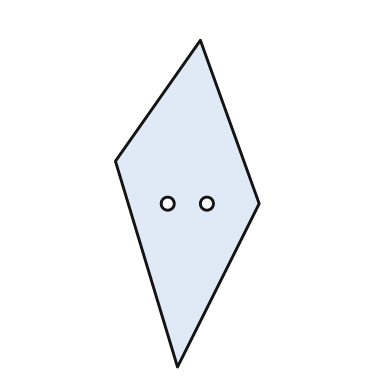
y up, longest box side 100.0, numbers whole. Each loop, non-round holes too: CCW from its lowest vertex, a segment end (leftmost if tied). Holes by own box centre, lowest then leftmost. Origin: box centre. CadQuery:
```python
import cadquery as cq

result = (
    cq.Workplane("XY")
    .moveTo(-3.0, -50.0)
    .lineTo(22.0, 0.0)
    .lineTo(4.0, 50.0)
    .lineTo(-22.0, 13.0)
    .close()
    .moveTo(-6.0, 0.0)
    .circle(2.0)
    .moveTo(6.0, 0.0)
    .circle(2.0)
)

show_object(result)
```